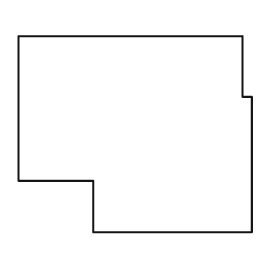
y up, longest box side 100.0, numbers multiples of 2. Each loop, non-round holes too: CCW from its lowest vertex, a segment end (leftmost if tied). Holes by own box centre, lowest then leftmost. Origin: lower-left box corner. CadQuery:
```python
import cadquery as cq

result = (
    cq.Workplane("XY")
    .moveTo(32.0, 0.0)
    .lineTo(100.0, 0.0)
    .lineTo(100.0, 58.0)
    .lineTo(96.0, 58.0)
    .lineTo(96.0, 84.0)
    .lineTo(0.0, 84.0)
    .lineTo(0.0, 22.0)
    .lineTo(32.0, 22.0)
    .close()
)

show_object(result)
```